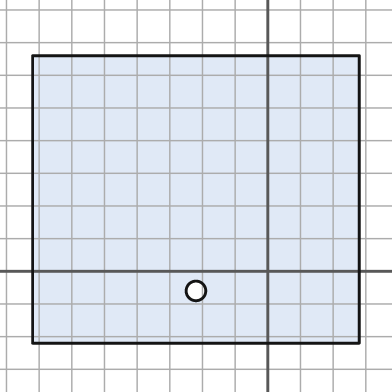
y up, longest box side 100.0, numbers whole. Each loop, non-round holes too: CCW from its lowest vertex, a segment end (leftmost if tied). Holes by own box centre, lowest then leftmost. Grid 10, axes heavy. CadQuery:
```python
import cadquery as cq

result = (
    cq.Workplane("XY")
    .moveTo(-72.0, -22.0)
    .lineTo(28.0, -22.0)
    .lineTo(28.0, 66.0)
    .lineTo(-72.0, 66.0)
    .close()
    .moveTo(-22.0, -6.0)
    .circle(3.0)
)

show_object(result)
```